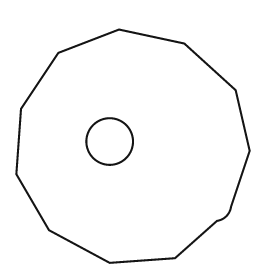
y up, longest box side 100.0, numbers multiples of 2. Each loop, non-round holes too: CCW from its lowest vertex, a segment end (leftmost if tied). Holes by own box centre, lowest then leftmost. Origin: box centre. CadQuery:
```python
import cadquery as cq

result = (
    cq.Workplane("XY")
    .moveTo(-10.0, -50.0)
    .lineTo(18.0, -48.0)
    .lineTo(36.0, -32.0)
    .threePointArc((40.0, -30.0), (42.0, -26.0))
    .lineTo(50.0, -2.0)
    .lineTo(44.0, 24.0)
    .lineTo(22.0, 44.0)
    .lineTo(-6.0, 50.0)
    .lineTo(-32.0, 40.0)
    .lineTo(-48.0, 16.0)
    .lineTo(-50.0, -12.0)
    .lineTo(-36.0, -36.0)
    .close()
    .moveTo(-10.0, 2.0)
    .circle(10.0)
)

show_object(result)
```